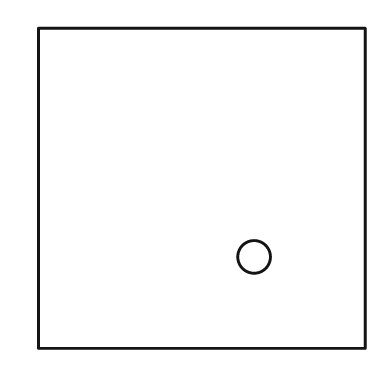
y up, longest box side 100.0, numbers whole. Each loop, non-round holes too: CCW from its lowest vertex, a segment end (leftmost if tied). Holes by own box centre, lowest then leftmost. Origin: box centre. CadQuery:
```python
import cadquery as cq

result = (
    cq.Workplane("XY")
    .moveTo(-50.0, -49.0)
    .lineTo(50.0, -49.0)
    .lineTo(50.0, 49.0)
    .lineTo(-50.0, 49.0)
    .close()
    .moveTo(16.0, -21.0)
    .circle(5.0)
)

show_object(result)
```